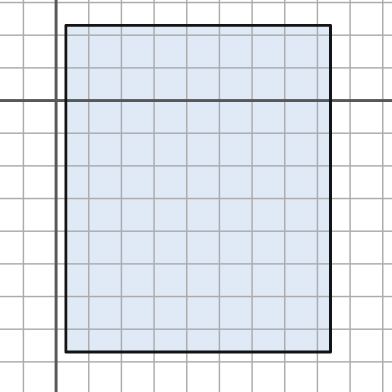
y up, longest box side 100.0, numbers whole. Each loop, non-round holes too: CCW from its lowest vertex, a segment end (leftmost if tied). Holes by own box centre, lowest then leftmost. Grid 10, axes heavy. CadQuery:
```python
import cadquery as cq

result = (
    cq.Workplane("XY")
    .moveTo(3.0, -77.0)
    .lineTo(84.0, -77.0)
    .lineTo(84.0, 23.0)
    .lineTo(3.0, 23.0)
    .close()
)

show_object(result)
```